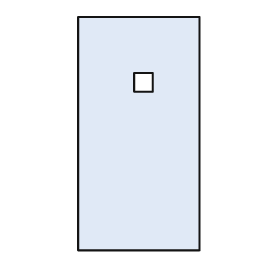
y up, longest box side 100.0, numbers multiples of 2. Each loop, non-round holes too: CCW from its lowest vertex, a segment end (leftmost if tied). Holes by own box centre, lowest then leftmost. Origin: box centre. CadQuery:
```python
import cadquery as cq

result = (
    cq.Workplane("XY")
    .moveTo(-26.0, -50.0)
    .lineTo(26.0, -50.0)
    .lineTo(26.0, 50.0)
    .lineTo(-26.0, 50.0)
    .close()
    .moveTo(-2.0, 18.0)
    .lineTo(6.0, 18.0)
    .lineTo(6.0, 26.0)
    .lineTo(-2.0, 26.0)
    .close()
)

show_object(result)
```